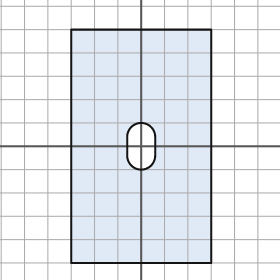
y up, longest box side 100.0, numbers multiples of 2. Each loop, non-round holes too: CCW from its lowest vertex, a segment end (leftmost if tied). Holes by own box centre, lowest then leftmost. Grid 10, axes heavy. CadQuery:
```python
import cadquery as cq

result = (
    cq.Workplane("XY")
    .moveTo(-30.0, -50.0)
    .lineTo(30.0, -50.0)
    .lineTo(30.0, 50.0)
    .lineTo(-30.0, 50.0)
    .close()
    .moveTo(-6.0, -4.0)
    .threePointArc((0.0, -10.0), (6.0, -4.0))
    .lineTo(6.0, 4.0)
    .threePointArc((0.0, 10.0), (-6.0, 4.0))
    .close()
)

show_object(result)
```